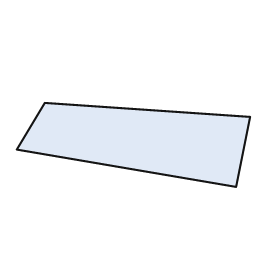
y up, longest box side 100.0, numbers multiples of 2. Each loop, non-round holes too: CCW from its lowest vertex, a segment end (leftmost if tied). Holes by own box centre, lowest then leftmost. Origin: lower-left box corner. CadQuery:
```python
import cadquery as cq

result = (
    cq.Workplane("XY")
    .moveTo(94.0, 0.0)
    .lineTo(100.0, 30.0)
    .lineTo(12.0, 36.0)
    .lineTo(0.0, 16.0)
    .close()
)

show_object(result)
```